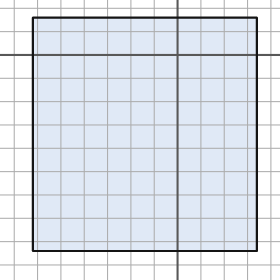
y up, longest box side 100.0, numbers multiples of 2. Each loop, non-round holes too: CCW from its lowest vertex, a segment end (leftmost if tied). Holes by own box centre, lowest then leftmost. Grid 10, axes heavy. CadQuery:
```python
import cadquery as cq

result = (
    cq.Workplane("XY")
    .moveTo(-62.0, -84.0)
    .lineTo(34.0, -84.0)
    .lineTo(34.0, 16.0)
    .lineTo(-62.0, 16.0)
    .close()
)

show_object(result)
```